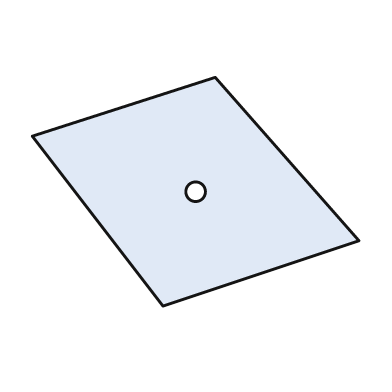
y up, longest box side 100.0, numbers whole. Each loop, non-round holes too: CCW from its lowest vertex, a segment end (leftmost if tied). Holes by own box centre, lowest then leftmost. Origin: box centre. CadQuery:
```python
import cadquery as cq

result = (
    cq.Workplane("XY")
    .moveTo(-10.0, -35.0)
    .lineTo(50.0, -15.0)
    .lineTo(6.0, 35.0)
    .lineTo(-50.0, 17.0)
    .close()
    .moveTo(0.0, 0.0)
    .circle(3.0)
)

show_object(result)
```